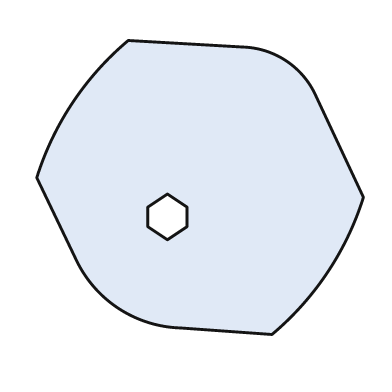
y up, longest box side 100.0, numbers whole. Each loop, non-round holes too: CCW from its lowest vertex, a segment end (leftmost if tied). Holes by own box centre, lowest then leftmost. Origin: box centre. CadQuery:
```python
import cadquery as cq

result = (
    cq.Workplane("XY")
    .moveTo(22.0, -45.0)
    .threePointArc((39.0, -26.0), (50.0, -3.0))
    .lineTo(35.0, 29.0)
    .threePointArc((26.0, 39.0), (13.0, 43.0))
    .lineTo(-22.0, 45.0)
    .threePointArc((-39.0, 26.0), (-50.0, 3.0))
    .lineTo(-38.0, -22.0)
    .threePointArc((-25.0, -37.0), (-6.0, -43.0))
    .close()
    .moveTo(-10.0, -16.0)
    .lineTo(-4.0, -12.0)
    .lineTo(-4.0, -6.0)
    .lineTo(-10.0, -2.0)
    .lineTo(-16.0, -6.0)
    .lineTo(-16.0, -12.0)
    .close()
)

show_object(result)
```